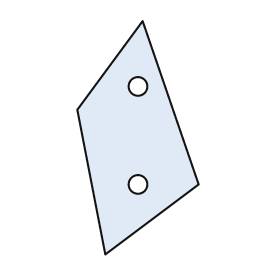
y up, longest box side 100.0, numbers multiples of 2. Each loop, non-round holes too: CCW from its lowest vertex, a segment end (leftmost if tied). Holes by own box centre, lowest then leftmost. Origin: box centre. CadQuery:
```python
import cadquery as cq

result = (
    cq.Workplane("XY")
    .moveTo(-14.0, -50.0)
    .lineTo(26.0, -20.0)
    .lineTo(2.0, 50.0)
    .lineTo(-26.0, 12.0)
    .close()
    .moveTo(0.0, -20.0)
    .circle(4.0)
    .moveTo(0.0, 22.0)
    .circle(4.0)
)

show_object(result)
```